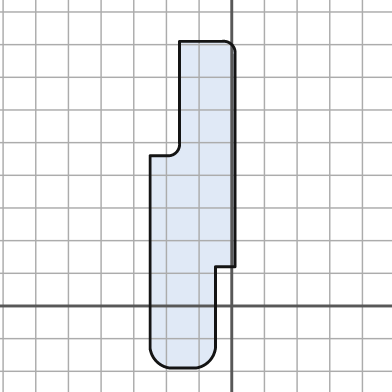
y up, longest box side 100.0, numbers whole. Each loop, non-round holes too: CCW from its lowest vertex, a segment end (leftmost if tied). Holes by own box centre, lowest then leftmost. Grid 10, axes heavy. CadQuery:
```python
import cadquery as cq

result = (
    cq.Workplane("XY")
    .moveTo(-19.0, -19.0)
    .lineTo(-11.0, -19.0)
    .threePointArc((-7.0, -17.0), (-5.0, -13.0))
    .lineTo(-5.0, 12.0)
    .lineTo(1.0, 12.0)
    .lineTo(1.0, 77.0)
    .threePointArc((0.0, 80.0), (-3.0, 81.0))
    .lineTo(-16.0, 81.0)
    .lineTo(-16.0, 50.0)
    .threePointArc((-17.0, 47.0), (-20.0, 46.0))
    .lineTo(-25.0, 46.0)
    .lineTo(-25.0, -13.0)
    .threePointArc((-23.0, -17.0), (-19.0, -19.0))
    .close()
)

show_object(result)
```